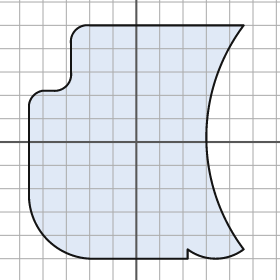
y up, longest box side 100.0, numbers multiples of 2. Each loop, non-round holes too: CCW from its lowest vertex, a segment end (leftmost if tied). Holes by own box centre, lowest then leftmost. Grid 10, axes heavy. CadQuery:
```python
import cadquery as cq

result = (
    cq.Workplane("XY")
    .moveTo(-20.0, -50.0)
    .lineTo(22.0, -50.0)
    .lineTo(22.0, -46.0)
    .threePointArc((34.0, -50.0), (46.0, -46.0))
    .threePointArc((30.0, 2.0), (46.0, 50.0))
    .lineTo(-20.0, 50.0)
    .threePointArc((-26.0, 48.0), (-28.0, 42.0))
    .lineTo(-28.0, 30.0)
    .threePointArc((-30.0, 24.0), (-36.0, 22.0))
    .lineTo(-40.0, 22.0)
    .threePointArc((-44.0, 20.0), (-46.0, 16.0))
    .lineTo(-46.0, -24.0)
    .threePointArc((-38.0, -42.0), (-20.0, -50.0))
    .close()
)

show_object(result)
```